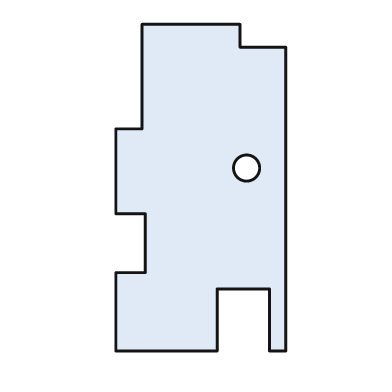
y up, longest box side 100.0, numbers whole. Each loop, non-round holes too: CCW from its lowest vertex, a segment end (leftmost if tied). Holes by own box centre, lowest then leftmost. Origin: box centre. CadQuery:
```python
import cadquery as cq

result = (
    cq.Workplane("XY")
    .moveTo(-26.0, -50.0)
    .lineTo(5.0, -50.0)
    .lineTo(5.0, -31.0)
    .lineTo(21.0, -31.0)
    .lineTo(21.0, -50.0)
    .lineTo(26.0, -50.0)
    .lineTo(26.0, 43.0)
    .lineTo(12.0, 43.0)
    .lineTo(12.0, 50.0)
    .lineTo(-18.0, 50.0)
    .lineTo(-18.0, 18.0)
    .lineTo(-26.0, 18.0)
    .lineTo(-26.0, -8.0)
    .lineTo(-17.0, -8.0)
    .lineTo(-17.0, -26.0)
    .lineTo(-26.0, -26.0)
    .close()
    .moveTo(14.0, 6.0)
    .circle(4.0)
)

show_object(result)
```